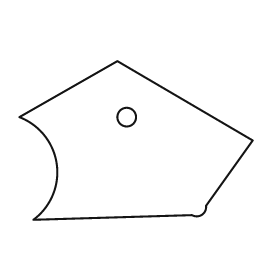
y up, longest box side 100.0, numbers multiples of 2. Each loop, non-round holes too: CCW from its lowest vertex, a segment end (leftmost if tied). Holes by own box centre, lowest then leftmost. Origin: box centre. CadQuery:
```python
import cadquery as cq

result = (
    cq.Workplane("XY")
    .moveTo(-44.0, -34.0)
    .lineTo(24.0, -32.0)
    .threePointArc((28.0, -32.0), (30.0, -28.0))
    .lineTo(50.0, 0.0)
    .lineTo(-8.0, 34.0)
    .lineTo(-50.0, 10.0)
    .threePointArc((-34.0, -10.0), (-44.0, -34.0))
    .close()
    .moveTo(-4.0, 10.0)
    .circle(4.0)
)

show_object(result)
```